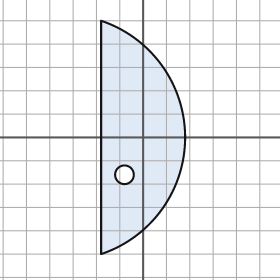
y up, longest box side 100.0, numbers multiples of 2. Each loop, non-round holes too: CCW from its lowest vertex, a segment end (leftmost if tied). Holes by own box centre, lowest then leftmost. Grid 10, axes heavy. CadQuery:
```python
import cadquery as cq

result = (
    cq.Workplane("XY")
    .moveTo(-18.0, -50.0)
    .threePointArc((18.0, 0.0), (-18.0, 50.0))
    .close()
    .moveTo(-8.0, -16.0)
    .circle(4.0)
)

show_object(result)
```